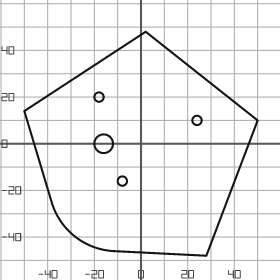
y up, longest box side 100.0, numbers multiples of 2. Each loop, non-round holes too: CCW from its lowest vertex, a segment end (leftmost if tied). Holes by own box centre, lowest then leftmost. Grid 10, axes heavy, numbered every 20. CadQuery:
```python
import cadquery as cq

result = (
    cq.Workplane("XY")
    .moveTo(28.0, -48.0)
    .lineTo(50.0, 10.0)
    .lineTo(2.0, 48.0)
    .lineTo(-50.0, 14.0)
    .lineTo(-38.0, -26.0)
    .threePointArc((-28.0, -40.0), (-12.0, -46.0))
    .close()
    .moveTo(-8.0, -16.0)
    .circle(2.0)
    .moveTo(-16.0, 0.0)
    .circle(4.0)
    .moveTo(24.0, 10.0)
    .circle(2.0)
    .moveTo(-18.0, 20.0)
    .circle(2.0)
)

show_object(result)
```